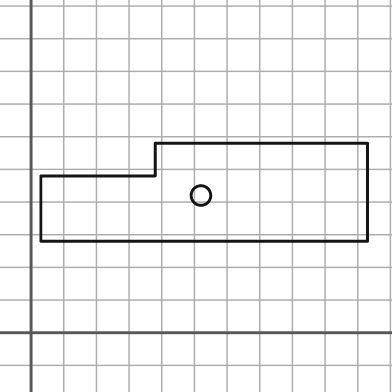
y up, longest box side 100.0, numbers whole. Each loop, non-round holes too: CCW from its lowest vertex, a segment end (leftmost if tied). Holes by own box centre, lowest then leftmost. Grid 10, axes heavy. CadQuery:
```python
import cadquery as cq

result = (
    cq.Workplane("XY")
    .moveTo(3.0, 28.0)
    .lineTo(103.0, 28.0)
    .lineTo(103.0, 58.0)
    .lineTo(38.0, 58.0)
    .lineTo(38.0, 48.0)
    .lineTo(3.0, 48.0)
    .close()
    .moveTo(52.0, 42.0)
    .circle(3.0)
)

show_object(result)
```